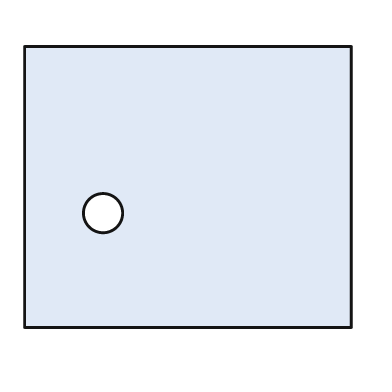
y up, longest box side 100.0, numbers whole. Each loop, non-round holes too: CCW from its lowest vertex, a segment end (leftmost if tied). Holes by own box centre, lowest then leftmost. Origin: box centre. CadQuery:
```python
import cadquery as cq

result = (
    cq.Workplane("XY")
    .moveTo(-50.0, -43.0)
    .lineTo(50.0, -43.0)
    .lineTo(50.0, 43.0)
    .lineTo(-50.0, 43.0)
    .close()
    .moveTo(-26.0, -8.0)
    .circle(6.0)
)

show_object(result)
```